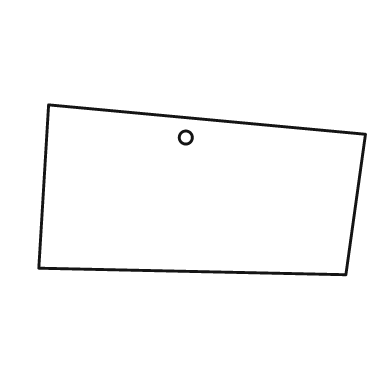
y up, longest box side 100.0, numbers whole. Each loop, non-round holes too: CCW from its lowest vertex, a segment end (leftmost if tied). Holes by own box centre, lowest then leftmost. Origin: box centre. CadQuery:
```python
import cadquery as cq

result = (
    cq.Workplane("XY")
    .moveTo(44.0, -26.0)
    .lineTo(50.0, 17.0)
    .lineTo(-47.0, 26.0)
    .lineTo(-50.0, -24.0)
    .close()
    .moveTo(-5.0, 16.0)
    .circle(2.0)
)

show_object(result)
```